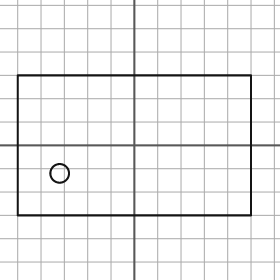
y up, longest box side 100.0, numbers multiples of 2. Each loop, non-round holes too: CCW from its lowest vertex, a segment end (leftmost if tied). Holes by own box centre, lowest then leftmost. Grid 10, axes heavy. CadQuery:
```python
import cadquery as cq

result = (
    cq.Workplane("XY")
    .moveTo(-50.0, -30.0)
    .lineTo(50.0, -30.0)
    .lineTo(50.0, 30.0)
    .lineTo(-50.0, 30.0)
    .close()
    .moveTo(-32.0, -12.0)
    .circle(4.0)
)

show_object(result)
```